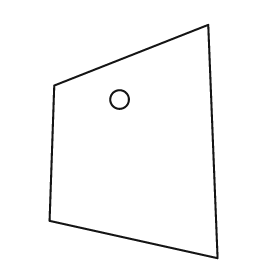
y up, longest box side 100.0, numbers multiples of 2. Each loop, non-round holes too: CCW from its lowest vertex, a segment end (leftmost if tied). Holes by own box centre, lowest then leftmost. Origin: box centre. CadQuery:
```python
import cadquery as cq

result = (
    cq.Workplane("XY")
    .moveTo(36.0, -50.0)
    .lineTo(32.0, 50.0)
    .lineTo(-34.0, 24.0)
    .lineTo(-36.0, -34.0)
    .close()
    .moveTo(-6.0, 18.0)
    .circle(4.0)
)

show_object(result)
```